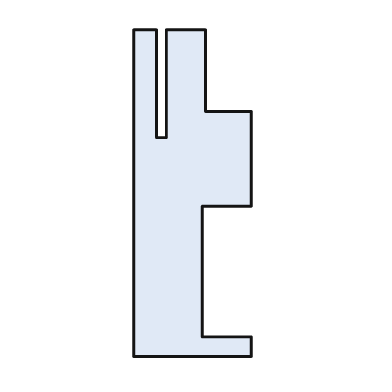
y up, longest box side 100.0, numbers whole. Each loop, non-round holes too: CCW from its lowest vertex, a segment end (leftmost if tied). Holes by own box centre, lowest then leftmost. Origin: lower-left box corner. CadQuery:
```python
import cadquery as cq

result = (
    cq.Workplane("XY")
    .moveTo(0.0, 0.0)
    .lineTo(36.0, 0.0)
    .lineTo(36.0, 6.0)
    .lineTo(21.0, 6.0)
    .lineTo(21.0, 46.0)
    .lineTo(36.0, 46.0)
    .lineTo(36.0, 75.0)
    .lineTo(22.0, 75.0)
    .lineTo(22.0, 100.0)
    .lineTo(10.0, 100.0)
    .lineTo(10.0, 67.0)
    .lineTo(7.0, 67.0)
    .lineTo(7.0, 100.0)
    .lineTo(0.0, 100.0)
    .close()
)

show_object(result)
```